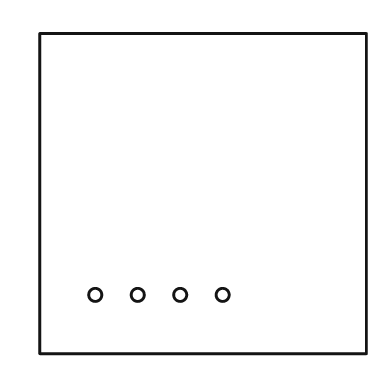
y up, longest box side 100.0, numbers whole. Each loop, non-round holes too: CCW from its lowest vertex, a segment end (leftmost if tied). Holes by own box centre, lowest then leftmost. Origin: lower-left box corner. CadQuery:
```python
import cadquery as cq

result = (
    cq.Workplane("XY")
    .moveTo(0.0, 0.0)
    .lineTo(100.0, 0.0)
    .lineTo(100.0, 98.0)
    .lineTo(0.0, 98.0)
    .close()
    .moveTo(17.0, 18.0)
    .circle(2.0)
    .moveTo(30.0, 18.0)
    .circle(2.0)
    .moveTo(43.0, 18.0)
    .circle(2.0)
    .moveTo(56.0, 18.0)
    .circle(2.0)
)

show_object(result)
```